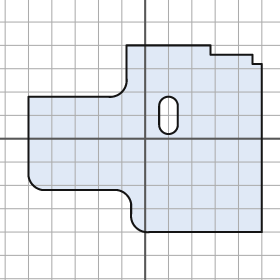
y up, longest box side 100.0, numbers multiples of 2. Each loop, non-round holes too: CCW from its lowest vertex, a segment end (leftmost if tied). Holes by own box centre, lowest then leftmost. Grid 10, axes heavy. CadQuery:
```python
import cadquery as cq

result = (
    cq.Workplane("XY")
    .moveTo(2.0, -40.0)
    .lineTo(50.0, -40.0)
    .lineTo(50.0, 32.0)
    .lineTo(46.0, 32.0)
    .lineTo(46.0, 36.0)
    .lineTo(28.0, 36.0)
    .lineTo(28.0, 40.0)
    .lineTo(-8.0, 40.0)
    .lineTo(-8.0, 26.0)
    .threePointArc((-10.0, 20.0), (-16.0, 18.0))
    .lineTo(-50.0, 18.0)
    .lineTo(-50.0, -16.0)
    .threePointArc((-48.0, -20.0), (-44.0, -22.0))
    .lineTo(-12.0, -22.0)
    .threePointArc((-8.0, -24.0), (-6.0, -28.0))
    .lineTo(-6.0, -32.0)
    .threePointArc((-4.0, -38.0), (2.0, -40.0))
    .close()
    .moveTo(6.0, 6.0)
    .threePointArc((10.0, 2.0), (14.0, 6.0))
    .lineTo(14.0, 14.0)
    .threePointArc((10.0, 18.0), (6.0, 14.0))
    .close()
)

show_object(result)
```